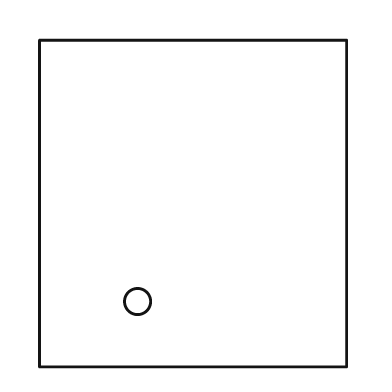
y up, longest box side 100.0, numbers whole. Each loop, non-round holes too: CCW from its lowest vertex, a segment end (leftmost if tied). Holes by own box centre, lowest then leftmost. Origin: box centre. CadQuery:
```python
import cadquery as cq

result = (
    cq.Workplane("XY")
    .moveTo(-47.0, -50.0)
    .lineTo(47.0, -50.0)
    .lineTo(47.0, 50.0)
    .lineTo(-47.0, 50.0)
    .close()
    .moveTo(-17.0, -30.0)
    .circle(4.0)
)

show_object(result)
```